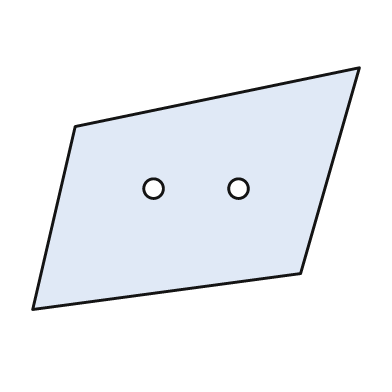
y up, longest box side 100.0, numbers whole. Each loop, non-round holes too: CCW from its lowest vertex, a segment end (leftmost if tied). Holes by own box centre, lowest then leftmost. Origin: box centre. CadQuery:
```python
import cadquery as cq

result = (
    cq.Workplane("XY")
    .moveTo(-50.0, -37.0)
    .lineTo(32.0, -26.0)
    .lineTo(50.0, 37.0)
    .lineTo(-37.0, 19.0)
    .close()
    .moveTo(-13.0, 0.0)
    .circle(3.0)
    .moveTo(13.0, 0.0)
    .circle(3.0)
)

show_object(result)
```